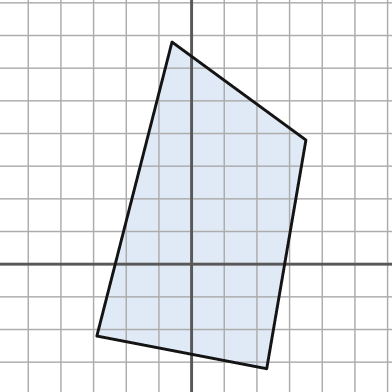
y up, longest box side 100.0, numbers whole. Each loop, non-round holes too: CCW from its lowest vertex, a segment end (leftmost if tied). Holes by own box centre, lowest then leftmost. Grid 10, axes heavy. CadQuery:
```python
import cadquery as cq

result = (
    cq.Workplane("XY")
    .moveTo(23.0, -32.0)
    .lineTo(35.0, 38.0)
    .lineTo(-6.0, 68.0)
    .lineTo(-29.0, -22.0)
    .close()
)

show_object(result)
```